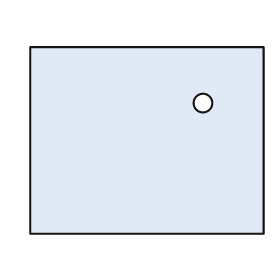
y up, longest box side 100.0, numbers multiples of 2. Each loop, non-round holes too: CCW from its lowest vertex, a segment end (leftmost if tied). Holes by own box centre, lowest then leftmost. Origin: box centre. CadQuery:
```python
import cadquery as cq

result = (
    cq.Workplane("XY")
    .moveTo(-50.0, -40.0)
    .lineTo(50.0, -40.0)
    .lineTo(50.0, 40.0)
    .lineTo(-50.0, 40.0)
    .close()
    .moveTo(24.0, 16.0)
    .circle(4.0)
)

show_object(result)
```